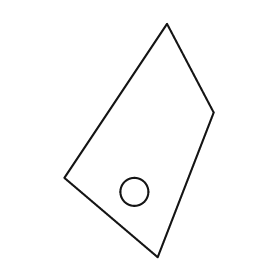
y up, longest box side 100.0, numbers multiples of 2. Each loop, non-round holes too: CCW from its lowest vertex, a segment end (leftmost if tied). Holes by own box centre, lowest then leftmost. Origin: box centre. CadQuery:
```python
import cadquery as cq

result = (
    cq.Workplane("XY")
    .moveTo(8.0, -50.0)
    .lineTo(32.0, 12.0)
    .lineTo(12.0, 50.0)
    .lineTo(-32.0, -16.0)
    .close()
    .moveTo(-2.0, -22.0)
    .circle(6.0)
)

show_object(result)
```